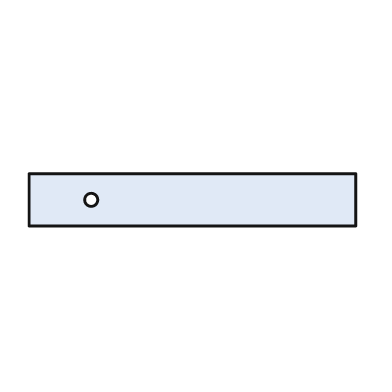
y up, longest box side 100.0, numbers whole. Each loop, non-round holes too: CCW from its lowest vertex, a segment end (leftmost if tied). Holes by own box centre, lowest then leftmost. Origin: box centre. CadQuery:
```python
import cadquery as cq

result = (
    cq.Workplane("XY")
    .moveTo(-50.0, -8.0)
    .lineTo(50.0, -8.0)
    .lineTo(50.0, 8.0)
    .lineTo(-50.0, 8.0)
    .close()
    .moveTo(-31.0, 0.0)
    .circle(2.0)
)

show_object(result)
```